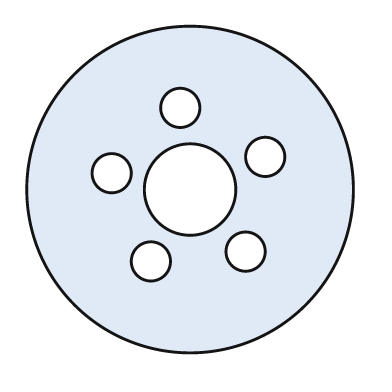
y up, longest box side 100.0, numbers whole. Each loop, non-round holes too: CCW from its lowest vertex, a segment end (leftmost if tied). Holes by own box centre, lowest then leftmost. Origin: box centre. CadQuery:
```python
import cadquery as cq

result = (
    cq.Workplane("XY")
    .moveTo(0.0, 0.0)
    .circle(50.0)
    .moveTo(-12.0, -22.0)
    .circle(6.0)
    .moveTo(17.0, -19.0)
    .circle(6.0)
    .moveTo(0.0, 0.0)
    .circle(14.0)
    .moveTo(-24.0, 5.0)
    .circle(6.0)
    .moveTo(23.0, 10.0)
    .circle(6.0)
    .moveTo(-3.0, 25.0)
    .circle(6.0)
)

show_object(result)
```